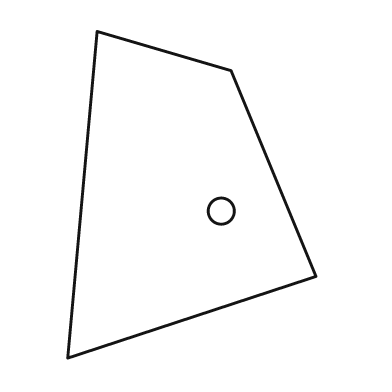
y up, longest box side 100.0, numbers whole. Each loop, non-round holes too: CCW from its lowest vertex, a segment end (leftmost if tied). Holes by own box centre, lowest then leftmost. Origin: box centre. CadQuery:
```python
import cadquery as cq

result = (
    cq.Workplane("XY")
    .moveTo(-38.0, -50.0)
    .lineTo(38.0, -25.0)
    .lineTo(12.0, 38.0)
    .lineTo(-29.0, 50.0)
    .close()
    .moveTo(9.0, -5.0)
    .circle(4.0)
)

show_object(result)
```